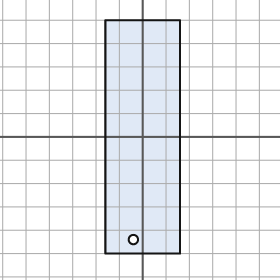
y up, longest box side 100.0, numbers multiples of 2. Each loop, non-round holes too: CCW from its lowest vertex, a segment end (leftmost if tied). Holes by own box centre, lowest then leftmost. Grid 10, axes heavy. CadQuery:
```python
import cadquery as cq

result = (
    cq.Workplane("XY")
    .moveTo(-16.0, -50.0)
    .lineTo(16.0, -50.0)
    .lineTo(16.0, 50.0)
    .lineTo(-16.0, 50.0)
    .close()
    .moveTo(-4.0, -44.0)
    .circle(2.0)
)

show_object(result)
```